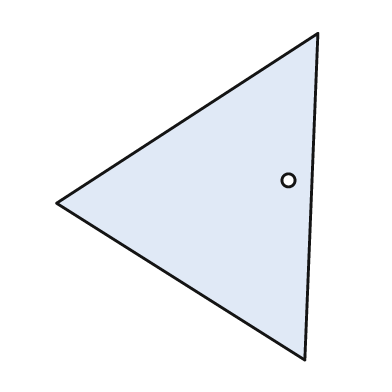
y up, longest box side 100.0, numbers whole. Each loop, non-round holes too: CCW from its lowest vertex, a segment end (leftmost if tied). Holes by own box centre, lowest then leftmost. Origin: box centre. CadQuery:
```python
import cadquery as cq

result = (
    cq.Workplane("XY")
    .moveTo(36.0, -50.0)
    .lineTo(40.0, 50.0)
    .lineTo(-40.0, -2.0)
    .close()
    .moveTo(31.0, 5.0)
    .circle(2.0)
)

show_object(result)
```